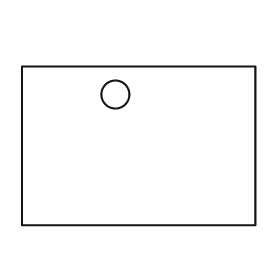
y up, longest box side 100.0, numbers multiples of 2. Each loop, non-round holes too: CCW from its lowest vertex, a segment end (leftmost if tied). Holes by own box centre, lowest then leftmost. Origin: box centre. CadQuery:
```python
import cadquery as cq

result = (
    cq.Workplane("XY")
    .moveTo(-50.0, -34.0)
    .lineTo(50.0, -34.0)
    .lineTo(50.0, 34.0)
    .lineTo(-50.0, 34.0)
    .close()
    .moveTo(-10.0, 22.0)
    .circle(6.0)
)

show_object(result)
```